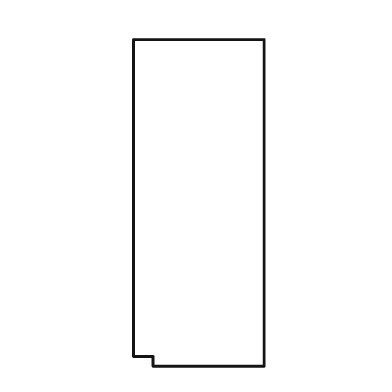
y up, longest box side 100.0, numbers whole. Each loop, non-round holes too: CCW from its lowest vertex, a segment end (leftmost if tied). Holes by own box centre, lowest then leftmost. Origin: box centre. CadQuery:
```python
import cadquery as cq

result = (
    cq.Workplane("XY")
    .moveTo(-14.0, -50.0)
    .lineTo(20.0, -50.0)
    .lineTo(20.0, 50.0)
    .lineTo(-20.0, 50.0)
    .lineTo(-20.0, -47.0)
    .lineTo(-14.0, -47.0)
    .close()
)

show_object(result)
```